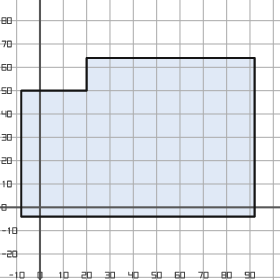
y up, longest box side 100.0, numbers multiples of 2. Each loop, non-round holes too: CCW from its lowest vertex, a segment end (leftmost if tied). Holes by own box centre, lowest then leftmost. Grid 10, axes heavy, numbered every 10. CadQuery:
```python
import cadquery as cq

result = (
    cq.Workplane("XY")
    .moveTo(-8.0, -4.0)
    .lineTo(92.0, -4.0)
    .lineTo(92.0, 64.0)
    .lineTo(20.0, 64.0)
    .lineTo(20.0, 50.0)
    .lineTo(-8.0, 50.0)
    .close()
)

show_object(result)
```